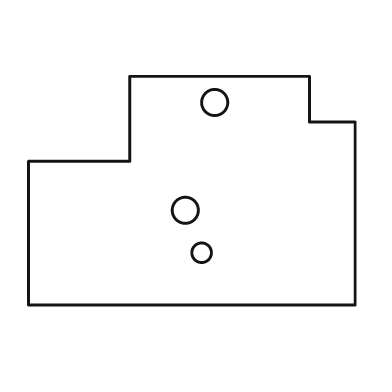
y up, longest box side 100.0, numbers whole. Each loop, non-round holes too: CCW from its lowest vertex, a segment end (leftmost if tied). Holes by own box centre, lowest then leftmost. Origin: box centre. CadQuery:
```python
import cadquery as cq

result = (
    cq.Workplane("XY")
    .moveTo(-50.0, -35.0)
    .lineTo(50.0, -35.0)
    .lineTo(50.0, 21.0)
    .lineTo(36.0, 21.0)
    .lineTo(36.0, 35.0)
    .lineTo(-19.0, 35.0)
    .lineTo(-19.0, 9.0)
    .lineTo(-50.0, 9.0)
    .close()
    .moveTo(3.0, -19.0)
    .circle(3.0)
    .moveTo(-2.0, -6.0)
    .circle(4.0)
    .moveTo(7.0, 27.0)
    .circle(4.0)
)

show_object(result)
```